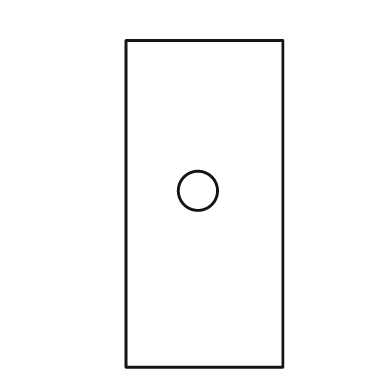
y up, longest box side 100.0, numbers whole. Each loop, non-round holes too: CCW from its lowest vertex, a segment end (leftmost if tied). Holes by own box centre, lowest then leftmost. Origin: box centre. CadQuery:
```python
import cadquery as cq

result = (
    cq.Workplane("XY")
    .moveTo(-24.0, -50.0)
    .lineTo(24.0, -50.0)
    .lineTo(24.0, 50.0)
    .lineTo(-24.0, 50.0)
    .close()
    .moveTo(-2.0, 4.0)
    .circle(6.0)
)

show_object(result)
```